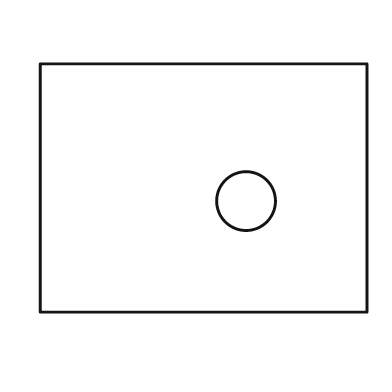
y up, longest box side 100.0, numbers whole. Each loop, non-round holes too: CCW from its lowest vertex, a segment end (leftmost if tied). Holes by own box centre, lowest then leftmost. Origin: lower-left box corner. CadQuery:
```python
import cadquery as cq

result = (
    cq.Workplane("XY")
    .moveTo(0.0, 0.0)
    .lineTo(100.0, 0.0)
    .lineTo(100.0, 76.0)
    .lineTo(0.0, 76.0)
    .close()
    .moveTo(63.0, 34.0)
    .circle(9.0)
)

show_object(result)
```